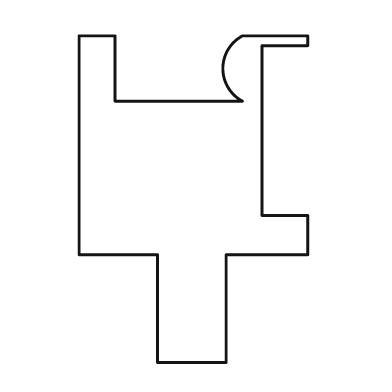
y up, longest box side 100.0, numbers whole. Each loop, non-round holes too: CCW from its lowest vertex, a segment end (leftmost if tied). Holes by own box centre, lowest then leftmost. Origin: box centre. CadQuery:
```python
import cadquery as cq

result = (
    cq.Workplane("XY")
    .moveTo(-11.0, -50.0)
    .lineTo(10.0, -50.0)
    .lineTo(10.0, -17.0)
    .lineTo(35.0, -17.0)
    .lineTo(35.0, -5.0)
    .lineTo(21.0, -5.0)
    .lineTo(21.0, 47.0)
    .lineTo(35.0, 47.0)
    .lineTo(35.0, 50.0)
    .lineTo(15.0, 50.0)
    .threePointArc((9.0, 40.0), (15.0, 30.0))
    .lineTo(-24.0, 30.0)
    .lineTo(-24.0, 50.0)
    .lineTo(-35.0, 50.0)
    .lineTo(-35.0, -17.0)
    .lineTo(-11.0, -17.0)
    .close()
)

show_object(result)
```